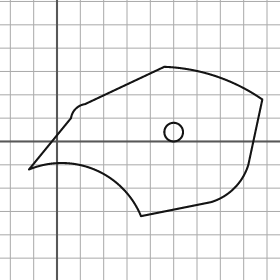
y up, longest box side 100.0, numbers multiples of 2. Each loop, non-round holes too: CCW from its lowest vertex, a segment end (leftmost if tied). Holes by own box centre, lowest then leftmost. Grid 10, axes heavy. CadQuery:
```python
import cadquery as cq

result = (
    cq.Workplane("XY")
    .moveTo(36.0, -32.0)
    .lineTo(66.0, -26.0)
    .threePointArc((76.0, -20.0), (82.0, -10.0))
    .lineTo(88.0, 18.0)
    .threePointArc((68.0, 28.0), (46.0, 32.0))
    .lineTo(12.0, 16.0)
    .threePointArc((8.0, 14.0), (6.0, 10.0))
    .lineTo(-12.0, -12.0)
    .threePointArc((16.0, -12.0), (36.0, -32.0))
    .close()
    .moveTo(50.0, 4.0)
    .circle(4.0)
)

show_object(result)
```